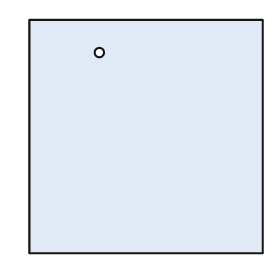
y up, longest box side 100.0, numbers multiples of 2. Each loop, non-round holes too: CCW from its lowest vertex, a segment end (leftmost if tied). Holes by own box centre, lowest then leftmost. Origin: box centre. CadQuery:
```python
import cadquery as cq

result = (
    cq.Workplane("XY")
    .moveTo(-50.0, -50.0)
    .lineTo(50.0, -50.0)
    .lineTo(50.0, 50.0)
    .lineTo(-50.0, 50.0)
    .close()
    .moveTo(-20.0, 36.0)
    .circle(2.0)
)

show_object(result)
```